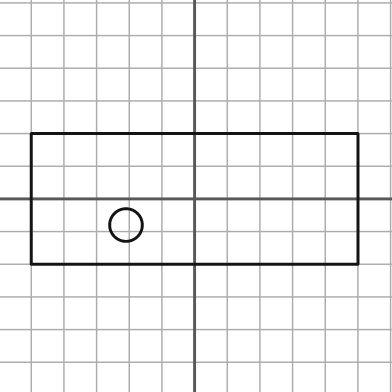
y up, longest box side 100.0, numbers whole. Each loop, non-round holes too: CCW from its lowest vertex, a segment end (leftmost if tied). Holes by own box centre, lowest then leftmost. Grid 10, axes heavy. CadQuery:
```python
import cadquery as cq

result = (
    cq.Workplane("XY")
    .moveTo(-50.0, -20.0)
    .lineTo(50.0, -20.0)
    .lineTo(50.0, 20.0)
    .lineTo(-50.0, 20.0)
    .close()
    .moveTo(-21.0, -8.0)
    .circle(5.0)
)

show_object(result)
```